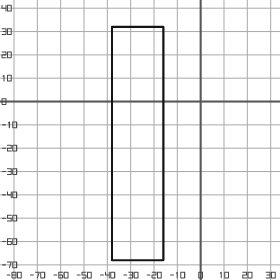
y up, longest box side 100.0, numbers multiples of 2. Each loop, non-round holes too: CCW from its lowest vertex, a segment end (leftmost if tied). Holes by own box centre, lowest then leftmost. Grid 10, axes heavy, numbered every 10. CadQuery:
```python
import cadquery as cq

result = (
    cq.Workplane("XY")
    .moveTo(-38.0, -68.0)
    .lineTo(-16.0, -68.0)
    .lineTo(-16.0, 32.0)
    .lineTo(-38.0, 32.0)
    .close()
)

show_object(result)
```